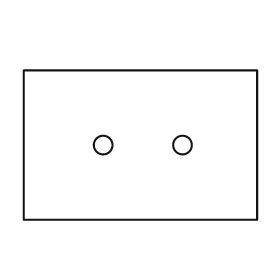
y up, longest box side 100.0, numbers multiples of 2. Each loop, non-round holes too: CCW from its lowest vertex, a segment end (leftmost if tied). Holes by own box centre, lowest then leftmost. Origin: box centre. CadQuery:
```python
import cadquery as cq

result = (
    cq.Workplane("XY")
    .moveTo(-50.0, -32.0)
    .lineTo(50.0, -32.0)
    .lineTo(50.0, 32.0)
    .lineTo(-50.0, 32.0)
    .close()
    .moveTo(-16.0, 0.0)
    .circle(4.0)
    .moveTo(18.0, 0.0)
    .circle(4.0)
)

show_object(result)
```